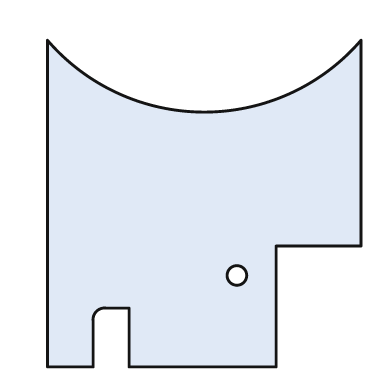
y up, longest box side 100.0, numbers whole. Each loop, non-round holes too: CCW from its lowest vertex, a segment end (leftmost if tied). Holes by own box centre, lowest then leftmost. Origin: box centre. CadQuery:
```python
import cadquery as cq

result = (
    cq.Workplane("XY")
    .moveTo(-48.0, -50.0)
    .lineTo(-34.0, -50.0)
    .lineTo(-34.0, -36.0)
    .threePointArc((-33.0, -33.0), (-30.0, -32.0))
    .lineTo(-23.0, -32.0)
    .lineTo(-23.0, -50.0)
    .lineTo(22.0, -50.0)
    .lineTo(22.0, -13.0)
    .lineTo(48.0, -13.0)
    .lineTo(48.0, 50.0)
    .threePointArc((0.0, 28.0), (-48.0, 50.0))
    .close()
    .moveTo(10.0, -22.0)
    .circle(3.0)
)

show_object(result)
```